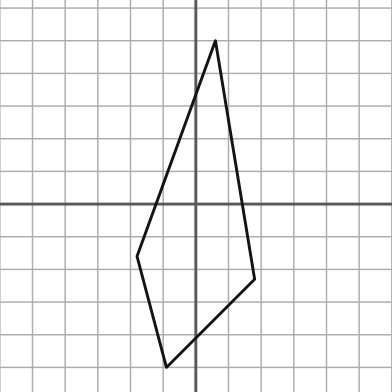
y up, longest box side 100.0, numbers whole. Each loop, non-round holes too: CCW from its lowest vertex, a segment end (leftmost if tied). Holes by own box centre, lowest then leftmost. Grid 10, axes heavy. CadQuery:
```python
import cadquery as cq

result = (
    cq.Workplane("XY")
    .moveTo(-9.0, -50.0)
    .lineTo(18.0, -23.0)
    .lineTo(6.0, 50.0)
    .lineTo(-18.0, -16.0)
    .close()
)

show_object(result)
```